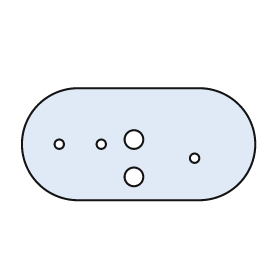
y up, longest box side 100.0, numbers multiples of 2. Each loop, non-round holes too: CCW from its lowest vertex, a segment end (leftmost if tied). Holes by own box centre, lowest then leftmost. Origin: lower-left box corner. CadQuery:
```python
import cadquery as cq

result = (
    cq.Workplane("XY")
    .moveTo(24.0, 0.0)
    .lineTo(76.0, 0.0)
    .threePointArc((100.0, 24.0), (76.0, 48.0))
    .lineTo(24.0, 48.0)
    .threePointArc((0.0, 24.0), (24.0, 0.0))
    .close()
    .moveTo(48.0, 10.0)
    .circle(4.0)
    .moveTo(74.0, 18.0)
    .circle(2.0)
    .moveTo(16.0, 24.0)
    .circle(2.0)
    .moveTo(34.0, 24.0)
    .circle(2.0)
    .moveTo(48.0, 26.0)
    .circle(4.0)
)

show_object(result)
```